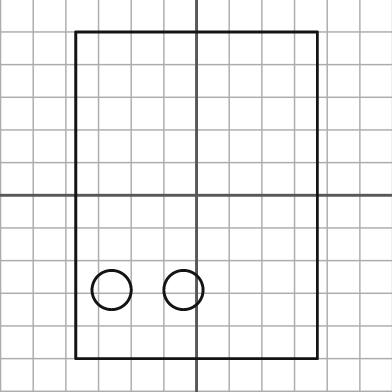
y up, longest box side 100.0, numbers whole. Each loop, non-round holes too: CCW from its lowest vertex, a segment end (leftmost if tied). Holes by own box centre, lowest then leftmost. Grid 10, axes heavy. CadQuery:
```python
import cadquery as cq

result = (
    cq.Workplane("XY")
    .moveTo(-37.0, -50.0)
    .lineTo(37.0, -50.0)
    .lineTo(37.0, 50.0)
    .lineTo(-37.0, 50.0)
    .close()
    .moveTo(-26.0, -29.0)
    .circle(6.0)
    .moveTo(-4.0, -29.0)
    .circle(6.0)
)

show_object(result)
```